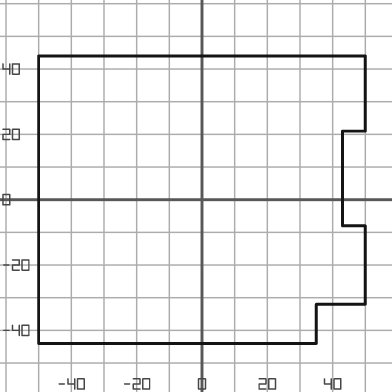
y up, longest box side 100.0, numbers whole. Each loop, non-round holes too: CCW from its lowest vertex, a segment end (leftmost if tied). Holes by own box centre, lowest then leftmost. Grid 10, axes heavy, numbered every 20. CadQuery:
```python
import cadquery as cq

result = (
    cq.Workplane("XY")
    .moveTo(-50.0, -44.0)
    .lineTo(35.0, -44.0)
    .lineTo(35.0, -32.0)
    .lineTo(50.0, -32.0)
    .lineTo(50.0, -8.0)
    .lineTo(43.0, -8.0)
    .lineTo(43.0, 21.0)
    .lineTo(50.0, 21.0)
    .lineTo(50.0, 44.0)
    .lineTo(-50.0, 44.0)
    .close()
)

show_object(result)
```